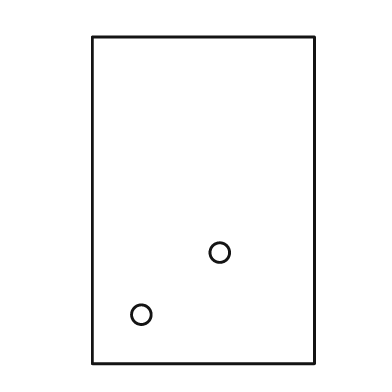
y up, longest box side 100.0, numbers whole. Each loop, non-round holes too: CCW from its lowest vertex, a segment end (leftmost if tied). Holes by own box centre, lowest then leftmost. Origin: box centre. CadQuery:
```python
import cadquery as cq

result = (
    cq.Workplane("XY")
    .moveTo(-34.0, -50.0)
    .lineTo(34.0, -50.0)
    .lineTo(34.0, 50.0)
    .lineTo(-34.0, 50.0)
    .close()
    .moveTo(-19.0, -35.0)
    .circle(3.0)
    .moveTo(5.0, -16.0)
    .circle(3.0)
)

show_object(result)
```